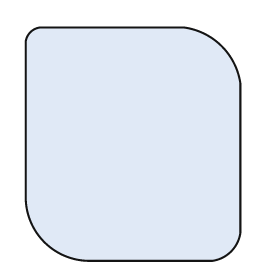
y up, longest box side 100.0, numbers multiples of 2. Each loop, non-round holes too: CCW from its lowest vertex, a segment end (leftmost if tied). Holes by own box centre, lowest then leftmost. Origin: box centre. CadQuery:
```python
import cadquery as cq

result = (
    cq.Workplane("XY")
    .moveTo(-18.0, -50.0)
    .lineTo(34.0, -50.0)
    .threePointArc((42.0, -46.0), (46.0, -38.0))
    .lineTo(46.0, 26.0)
    .threePointArc((38.0, 42.0), (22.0, 50.0))
    .lineTo(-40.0, 50.0)
    .threePointArc((-44.0, 48.0), (-46.0, 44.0))
    .lineTo(-46.0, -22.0)
    .threePointArc((-38.0, -42.0), (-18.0, -50.0))
    .close()
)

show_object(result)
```